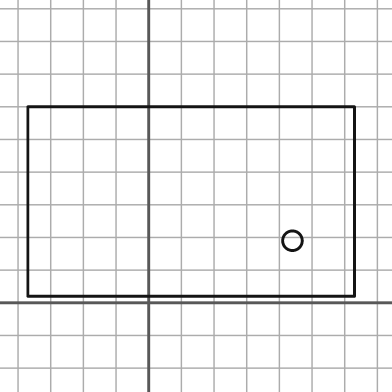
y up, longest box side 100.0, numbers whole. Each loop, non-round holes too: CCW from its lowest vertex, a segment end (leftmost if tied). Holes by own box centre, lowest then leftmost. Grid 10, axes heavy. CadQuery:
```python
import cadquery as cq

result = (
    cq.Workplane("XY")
    .moveTo(-37.0, 2.0)
    .lineTo(63.0, 2.0)
    .lineTo(63.0, 60.0)
    .lineTo(-37.0, 60.0)
    .close()
    .moveTo(44.0, 19.0)
    .circle(3.0)
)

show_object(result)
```